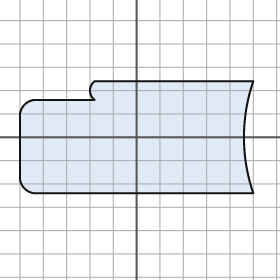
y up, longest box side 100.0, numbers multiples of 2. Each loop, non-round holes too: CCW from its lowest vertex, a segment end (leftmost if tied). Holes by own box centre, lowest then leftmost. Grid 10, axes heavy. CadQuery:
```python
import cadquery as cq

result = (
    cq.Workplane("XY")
    .moveTo(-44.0, -24.0)
    .lineTo(50.0, -24.0)
    .threePointArc((46.0, 0.0), (50.0, 24.0))
    .lineTo(-18.0, 24.0)
    .threePointArc((-20.0, 20.0), (-18.0, 16.0))
    .lineTo(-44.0, 16.0)
    .threePointArc((-48.0, 14.0), (-50.0, 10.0))
    .lineTo(-50.0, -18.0)
    .threePointArc((-48.0, -22.0), (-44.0, -24.0))
    .close()
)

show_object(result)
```